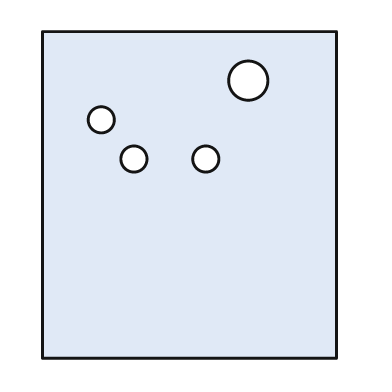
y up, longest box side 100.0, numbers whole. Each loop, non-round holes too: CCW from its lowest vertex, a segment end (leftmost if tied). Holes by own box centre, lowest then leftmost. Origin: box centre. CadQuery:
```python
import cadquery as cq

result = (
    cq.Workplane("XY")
    .moveTo(-45.0, -50.0)
    .lineTo(45.0, -50.0)
    .lineTo(45.0, 50.0)
    .lineTo(-45.0, 50.0)
    .close()
    .moveTo(-17.0, 11.0)
    .circle(4.0)
    .moveTo(5.0, 11.0)
    .circle(4.0)
    .moveTo(-27.0, 23.0)
    .circle(4.0)
    .moveTo(18.0, 35.0)
    .circle(6.0)
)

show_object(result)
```